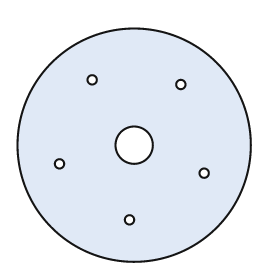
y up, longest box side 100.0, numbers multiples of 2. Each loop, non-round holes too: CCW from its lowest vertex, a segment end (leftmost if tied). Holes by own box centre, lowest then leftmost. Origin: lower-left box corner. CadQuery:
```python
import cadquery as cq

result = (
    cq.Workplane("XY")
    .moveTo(50.0, 50.0)
    .circle(50.0)
    .moveTo(48.0, 18.0)
    .circle(2.0)
    .moveTo(80.0, 38.0)
    .circle(2.0)
    .moveTo(18.0, 42.0)
    .circle(2.0)
    .moveTo(50.0, 50.0)
    .circle(8.0)
    .moveTo(70.0, 76.0)
    .circle(2.0)
    .moveTo(32.0, 78.0)
    .circle(2.0)
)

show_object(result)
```